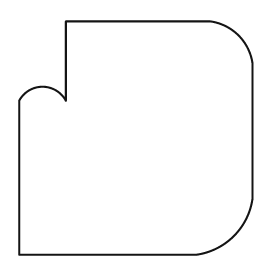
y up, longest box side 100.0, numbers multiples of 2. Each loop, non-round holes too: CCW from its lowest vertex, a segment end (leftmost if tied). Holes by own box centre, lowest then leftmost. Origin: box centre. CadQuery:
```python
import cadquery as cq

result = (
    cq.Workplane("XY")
    .moveTo(-50.0, -50.0)
    .lineTo(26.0, -50.0)
    .threePointArc((42.0, -42.0), (50.0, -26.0))
    .lineTo(50.0, 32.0)
    .threePointArc((44.0, 44.0), (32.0, 50.0))
    .lineTo(-30.0, 50.0)
    .lineTo(-30.0, 16.0)
    .threePointArc((-40.0, 22.0), (-50.0, 16.0))
    .close()
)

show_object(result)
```